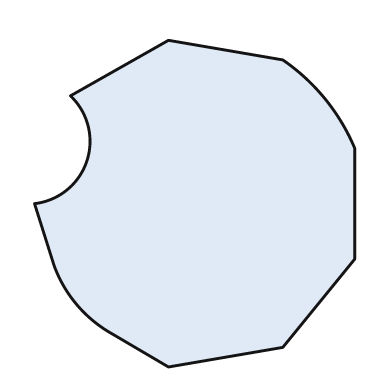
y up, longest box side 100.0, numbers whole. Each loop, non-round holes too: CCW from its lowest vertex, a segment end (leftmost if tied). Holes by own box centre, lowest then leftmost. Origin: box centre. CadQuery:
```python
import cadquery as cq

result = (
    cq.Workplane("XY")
    .moveTo(-8.0, -50.0)
    .lineTo(27.0, -44.0)
    .lineTo(49.0, -17.0)
    .lineTo(49.0, 17.0)
    .threePointArc((40.0, 32.0), (27.0, 44.0))
    .lineTo(-8.0, 50.0)
    .lineTo(-38.0, 33.0)
    .threePointArc((-33.0, 13.0), (-49.0, 0.0))
    .lineTo(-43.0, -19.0)
    .threePointArc((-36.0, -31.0), (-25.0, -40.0))
    .close()
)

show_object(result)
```